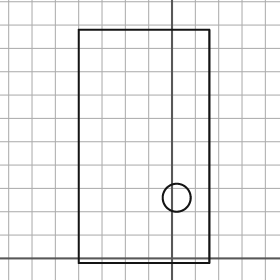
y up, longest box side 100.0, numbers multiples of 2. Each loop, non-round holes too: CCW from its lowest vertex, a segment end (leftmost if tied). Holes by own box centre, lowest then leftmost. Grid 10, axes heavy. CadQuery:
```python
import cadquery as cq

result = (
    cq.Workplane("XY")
    .moveTo(-40.0, -2.0)
    .lineTo(16.0, -2.0)
    .lineTo(16.0, 98.0)
    .lineTo(-40.0, 98.0)
    .close()
    .moveTo(2.0, 26.0)
    .circle(6.0)
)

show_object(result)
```